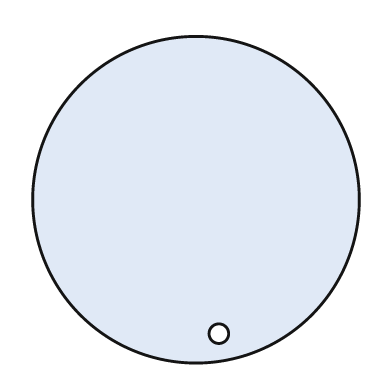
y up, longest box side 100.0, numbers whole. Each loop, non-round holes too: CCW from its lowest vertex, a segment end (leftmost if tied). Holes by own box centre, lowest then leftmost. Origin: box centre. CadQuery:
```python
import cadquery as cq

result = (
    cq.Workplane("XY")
    .moveTo(0.0, 0.0)
    .circle(50.0)
    .moveTo(7.0, -41.0)
    .circle(3.0)
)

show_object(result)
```